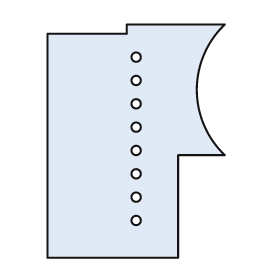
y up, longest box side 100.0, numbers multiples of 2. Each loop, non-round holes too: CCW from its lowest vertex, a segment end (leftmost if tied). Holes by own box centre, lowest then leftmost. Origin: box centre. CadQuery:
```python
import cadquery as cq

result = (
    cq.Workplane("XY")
    .moveTo(-38.0, -50.0)
    .lineTo(18.0, -50.0)
    .lineTo(18.0, -6.0)
    .lineTo(38.0, -6.0)
    .threePointArc((26.0, 22.0), (38.0, 50.0))
    .lineTo(-4.0, 50.0)
    .lineTo(-4.0, 46.0)
    .lineTo(-38.0, 46.0)
    .close()
    .moveTo(0.0, -34.0)
    .circle(2.0)
    .moveTo(0.0, -24.0)
    .circle(2.0)
    .moveTo(0.0, -14.0)
    .circle(2.0)
    .moveTo(0.0, -4.0)
    .circle(2.0)
    .moveTo(0.0, 6.0)
    .circle(2.0)
    .moveTo(0.0, 16.0)
    .circle(2.0)
    .moveTo(0.0, 26.0)
    .circle(2.0)
    .moveTo(0.0, 36.0)
    .circle(2.0)
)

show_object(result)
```